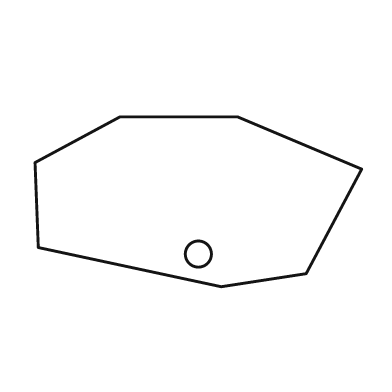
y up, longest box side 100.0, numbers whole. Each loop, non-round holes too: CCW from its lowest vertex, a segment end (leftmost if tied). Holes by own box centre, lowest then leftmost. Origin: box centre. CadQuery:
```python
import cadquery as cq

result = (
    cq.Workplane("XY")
    .moveTo(7.0, -26.0)
    .lineTo(33.0, -22.0)
    .lineTo(50.0, 10.0)
    .lineTo(12.0, 26.0)
    .lineTo(-24.0, 26.0)
    .lineTo(-50.0, 12.0)
    .lineTo(-49.0, -14.0)
    .close()
    .moveTo(0.0, -16.0)
    .circle(4.0)
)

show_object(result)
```